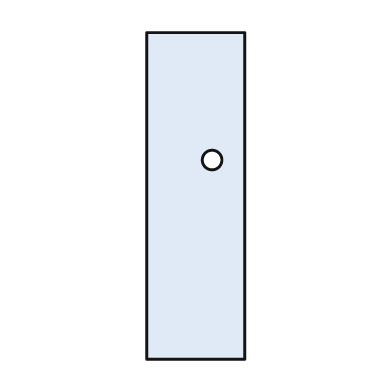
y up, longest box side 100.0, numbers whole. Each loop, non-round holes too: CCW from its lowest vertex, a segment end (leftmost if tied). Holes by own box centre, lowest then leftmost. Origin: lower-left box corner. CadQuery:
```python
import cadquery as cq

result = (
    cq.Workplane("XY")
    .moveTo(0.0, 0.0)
    .lineTo(30.0, 0.0)
    .lineTo(30.0, 100.0)
    .lineTo(0.0, 100.0)
    .close()
    .moveTo(20.0, 61.0)
    .circle(3.0)
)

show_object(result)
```